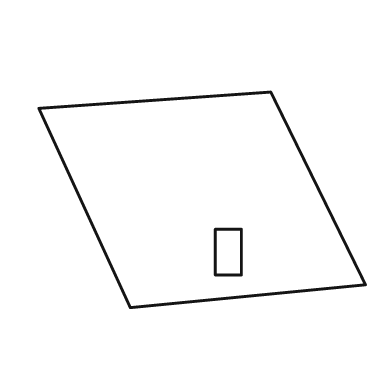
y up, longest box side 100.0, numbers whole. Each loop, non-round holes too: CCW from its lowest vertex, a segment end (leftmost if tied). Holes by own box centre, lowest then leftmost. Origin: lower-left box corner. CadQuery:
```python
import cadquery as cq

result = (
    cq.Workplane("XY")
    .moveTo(28.0, 0.0)
    .lineTo(100.0, 7.0)
    .lineTo(71.0, 66.0)
    .lineTo(0.0, 61.0)
    .close()
    .moveTo(54.0, 10.0)
    .lineTo(62.0, 10.0)
    .lineTo(62.0, 24.0)
    .lineTo(54.0, 24.0)
    .close()
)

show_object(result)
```